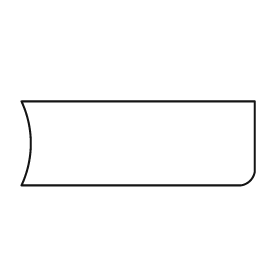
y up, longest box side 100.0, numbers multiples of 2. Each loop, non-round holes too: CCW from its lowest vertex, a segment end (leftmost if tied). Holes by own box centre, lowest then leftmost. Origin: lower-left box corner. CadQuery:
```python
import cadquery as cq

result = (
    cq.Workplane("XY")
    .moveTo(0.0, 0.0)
    .lineTo(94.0, 0.0)
    .threePointArc((98.0, 2.0), (100.0, 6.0))
    .lineTo(100.0, 36.0)
    .lineTo(0.0, 36.0)
    .threePointArc((4.0, 18.0), (0.0, 0.0))
    .close()
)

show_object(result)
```